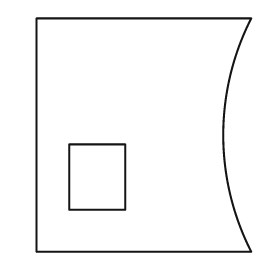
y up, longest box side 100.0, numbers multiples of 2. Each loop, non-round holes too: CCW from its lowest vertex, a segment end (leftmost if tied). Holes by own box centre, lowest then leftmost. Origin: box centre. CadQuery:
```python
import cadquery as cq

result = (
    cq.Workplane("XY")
    .moveTo(-46.0, -50.0)
    .lineTo(46.0, -50.0)
    .threePointArc((34.0, 0.0), (46.0, 50.0))
    .lineTo(-46.0, 50.0)
    .close()
    .moveTo(-32.0, -32.0)
    .lineTo(-8.0, -32.0)
    .lineTo(-8.0, -4.0)
    .lineTo(-32.0, -4.0)
    .close()
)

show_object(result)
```